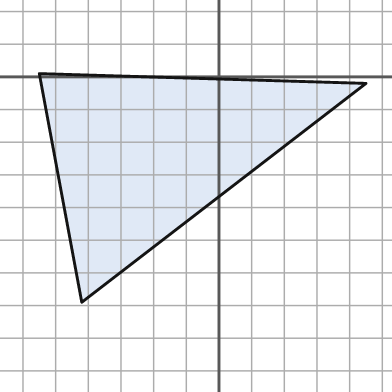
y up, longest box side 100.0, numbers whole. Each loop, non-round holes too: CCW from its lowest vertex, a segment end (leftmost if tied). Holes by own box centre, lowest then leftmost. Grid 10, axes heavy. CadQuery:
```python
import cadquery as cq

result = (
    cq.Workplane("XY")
    .moveTo(-42.0, -69.0)
    .lineTo(45.0, -2.0)
    .lineTo(-55.0, 1.0)
    .close()
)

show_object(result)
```